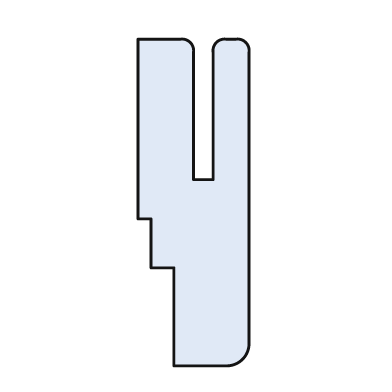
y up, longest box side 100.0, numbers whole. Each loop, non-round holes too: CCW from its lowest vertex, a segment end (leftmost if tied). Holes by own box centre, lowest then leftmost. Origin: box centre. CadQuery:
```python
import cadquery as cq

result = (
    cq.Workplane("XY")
    .moveTo(-6.0, -50.0)
    .lineTo(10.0, -50.0)
    .threePointArc((15.0, -48.0), (17.0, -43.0))
    .lineTo(17.0, 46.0)
    .threePointArc((16.0, 49.0), (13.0, 50.0))
    .lineTo(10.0, 50.0)
    .threePointArc((7.0, 49.0), (6.0, 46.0))
    .lineTo(6.0, 7.0)
    .lineTo(0.0, 7.0)
    .lineTo(0.0, 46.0)
    .threePointArc((-1.0, 49.0), (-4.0, 50.0))
    .lineTo(-17.0, 50.0)
    .lineTo(-17.0, -5.0)
    .lineTo(-13.0, -5.0)
    .lineTo(-13.0, -20.0)
    .lineTo(-6.0, -20.0)
    .close()
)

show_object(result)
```